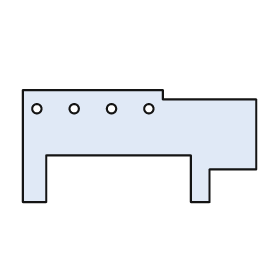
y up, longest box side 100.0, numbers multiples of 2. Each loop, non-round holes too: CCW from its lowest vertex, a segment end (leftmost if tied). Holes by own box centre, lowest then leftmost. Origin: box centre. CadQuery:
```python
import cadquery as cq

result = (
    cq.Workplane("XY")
    .moveTo(-50.0, -24.0)
    .lineTo(-40.0, -24.0)
    .lineTo(-40.0, -4.0)
    .lineTo(22.0, -4.0)
    .lineTo(22.0, -24.0)
    .lineTo(30.0, -24.0)
    .lineTo(30.0, -10.0)
    .lineTo(50.0, -10.0)
    .lineTo(50.0, 20.0)
    .lineTo(10.0, 20.0)
    .lineTo(10.0, 24.0)
    .lineTo(-50.0, 24.0)
    .close()
    .moveTo(-44.0, 16.0)
    .circle(2.0)
    .moveTo(-28.0, 16.0)
    .circle(2.0)
    .moveTo(-12.0, 16.0)
    .circle(2.0)
    .moveTo(4.0, 16.0)
    .circle(2.0)
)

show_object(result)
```